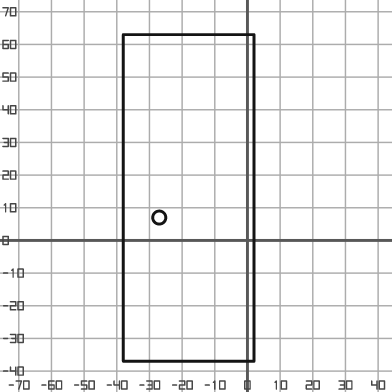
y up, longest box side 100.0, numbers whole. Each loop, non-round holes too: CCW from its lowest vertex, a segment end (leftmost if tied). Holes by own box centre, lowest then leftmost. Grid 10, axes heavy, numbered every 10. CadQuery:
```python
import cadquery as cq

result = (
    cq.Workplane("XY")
    .moveTo(-38.0, -37.0)
    .lineTo(2.0, -37.0)
    .lineTo(2.0, 63.0)
    .lineTo(-38.0, 63.0)
    .close()
    .moveTo(-27.0, 7.0)
    .circle(2.0)
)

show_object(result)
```